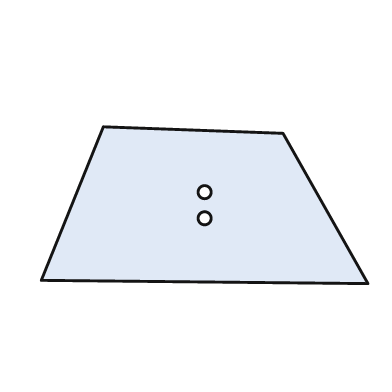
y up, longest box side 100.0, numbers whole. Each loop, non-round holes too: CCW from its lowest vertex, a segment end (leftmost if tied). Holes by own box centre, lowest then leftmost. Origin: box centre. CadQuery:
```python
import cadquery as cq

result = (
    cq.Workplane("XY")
    .moveTo(50.0, -24.0)
    .lineTo(24.0, 22.0)
    .lineTo(-31.0, 24.0)
    .lineTo(-50.0, -23.0)
    .close()
    .moveTo(0.0, -4.0)
    .circle(2.0)
    .moveTo(0.0, 4.0)
    .circle(2.0)
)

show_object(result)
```